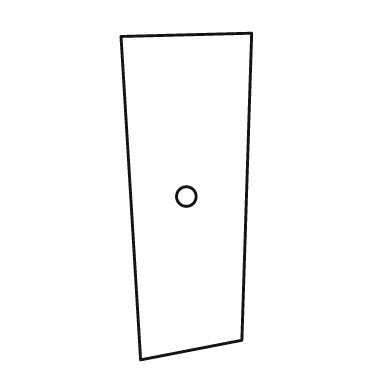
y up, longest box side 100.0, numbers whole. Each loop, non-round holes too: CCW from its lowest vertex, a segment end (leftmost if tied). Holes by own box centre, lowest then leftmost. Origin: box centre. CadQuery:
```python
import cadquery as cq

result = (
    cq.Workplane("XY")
    .moveTo(-14.0, -50.0)
    .lineTo(17.0, -44.0)
    .lineTo(20.0, 50.0)
    .lineTo(-20.0, 49.0)
    .close()
    .moveTo(0.0, 0.0)
    .circle(3.0)
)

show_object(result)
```